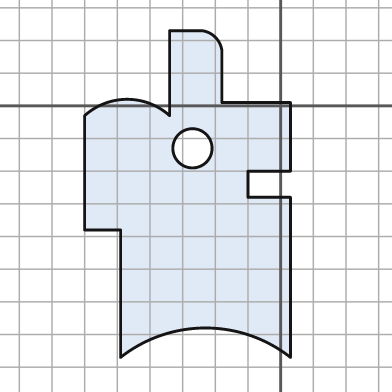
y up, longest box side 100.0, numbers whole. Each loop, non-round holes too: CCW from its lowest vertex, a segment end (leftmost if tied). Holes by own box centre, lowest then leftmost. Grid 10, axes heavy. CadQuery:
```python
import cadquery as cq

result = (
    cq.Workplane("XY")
    .moveTo(-49.0, -77.0)
    .threePointArc((-23.0, -68.0), (3.0, -77.0))
    .lineTo(3.0, -28.0)
    .lineTo(-10.0, -28.0)
    .lineTo(-10.0, -20.0)
    .lineTo(3.0, -20.0)
    .lineTo(3.0, 1.0)
    .lineTo(-18.0, 1.0)
    .lineTo(-18.0, 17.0)
    .threePointArc((-20.0, 21.0), (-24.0, 23.0))
    .lineTo(-34.0, 23.0)
    .lineTo(-34.0, -3.0)
    .threePointArc((-47.0, 2.0), (-60.0, -3.0))
    .lineTo(-60.0, -38.0)
    .lineTo(-49.0, -38.0)
    .close()
    .moveTo(-27.0, -13.0)
    .circle(6.0)
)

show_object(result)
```